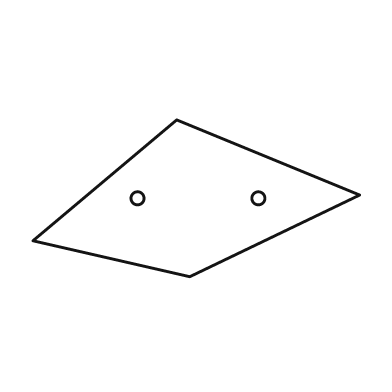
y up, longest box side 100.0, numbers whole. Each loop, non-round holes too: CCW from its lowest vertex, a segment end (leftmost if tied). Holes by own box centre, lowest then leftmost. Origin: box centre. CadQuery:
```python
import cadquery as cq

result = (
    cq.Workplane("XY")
    .moveTo(-2.0, -24.0)
    .lineTo(50.0, 1.0)
    .lineTo(-6.0, 24.0)
    .lineTo(-50.0, -13.0)
    .close()
    .moveTo(-18.0, 0.0)
    .circle(2.0)
    .moveTo(19.0, 0.0)
    .circle(2.0)
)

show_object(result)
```